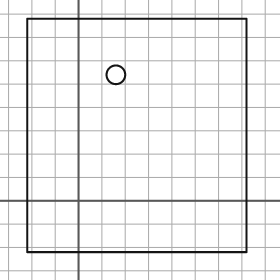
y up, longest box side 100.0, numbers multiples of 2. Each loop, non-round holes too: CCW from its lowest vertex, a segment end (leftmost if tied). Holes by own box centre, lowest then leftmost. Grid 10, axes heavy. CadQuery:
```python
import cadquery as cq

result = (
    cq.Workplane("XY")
    .moveTo(-22.0, -22.0)
    .lineTo(72.0, -22.0)
    .lineTo(72.0, 78.0)
    .lineTo(-22.0, 78.0)
    .close()
    .moveTo(16.0, 54.0)
    .circle(4.0)
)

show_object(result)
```